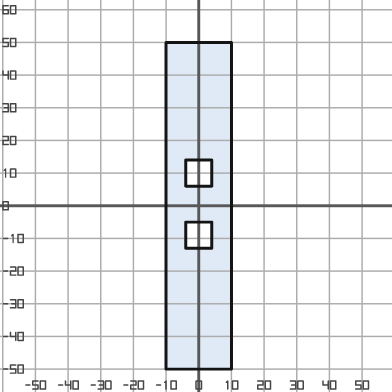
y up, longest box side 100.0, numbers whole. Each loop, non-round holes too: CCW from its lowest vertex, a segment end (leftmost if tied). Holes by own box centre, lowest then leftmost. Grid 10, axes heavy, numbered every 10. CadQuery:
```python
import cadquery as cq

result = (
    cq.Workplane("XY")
    .moveTo(-10.0, -50.0)
    .lineTo(10.0, -50.0)
    .lineTo(10.0, 50.0)
    .lineTo(-10.0, 50.0)
    .close()
    .moveTo(-4.0, -13.0)
    .lineTo(4.0, -13.0)
    .lineTo(4.0, -5.0)
    .lineTo(-4.0, -5.0)
    .close()
    .moveTo(-4.0, 6.0)
    .lineTo(4.0, 6.0)
    .lineTo(4.0, 14.0)
    .lineTo(-4.0, 14.0)
    .close()
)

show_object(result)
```